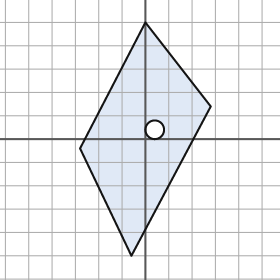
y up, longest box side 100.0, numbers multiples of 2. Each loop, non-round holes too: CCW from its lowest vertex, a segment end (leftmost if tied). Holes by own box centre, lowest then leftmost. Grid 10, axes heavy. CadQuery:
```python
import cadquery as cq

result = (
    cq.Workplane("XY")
    .moveTo(-6.0, -50.0)
    .lineTo(28.0, 14.0)
    .lineTo(0.0, 50.0)
    .lineTo(-28.0, -4.0)
    .close()
    .moveTo(4.0, 4.0)
    .circle(4.0)
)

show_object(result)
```